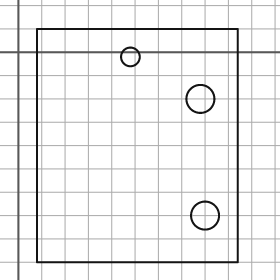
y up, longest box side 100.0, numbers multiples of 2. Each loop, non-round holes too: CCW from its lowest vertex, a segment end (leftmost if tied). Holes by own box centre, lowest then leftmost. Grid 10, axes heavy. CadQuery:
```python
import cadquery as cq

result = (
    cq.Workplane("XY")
    .moveTo(8.0, -90.0)
    .lineTo(94.0, -90.0)
    .lineTo(94.0, 10.0)
    .lineTo(8.0, 10.0)
    .close()
    .moveTo(80.0, -70.0)
    .circle(6.0)
    .moveTo(78.0, -20.0)
    .circle(6.0)
    .moveTo(48.0, -2.0)
    .circle(4.0)
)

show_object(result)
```